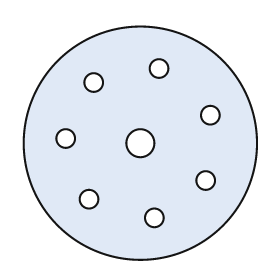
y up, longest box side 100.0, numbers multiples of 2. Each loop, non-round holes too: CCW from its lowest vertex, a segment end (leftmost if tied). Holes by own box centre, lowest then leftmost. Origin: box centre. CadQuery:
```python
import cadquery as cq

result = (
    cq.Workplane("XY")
    .moveTo(0.0, 0.0)
    .circle(50.0)
    .moveTo(6.0, -32.0)
    .circle(4.0)
    .moveTo(-22.0, -24.0)
    .circle(4.0)
    .moveTo(28.0, -16.0)
    .circle(4.0)
    .moveTo(0.0, 0.0)
    .circle(6.0)
    .moveTo(-32.0, 2.0)
    .circle(4.0)
    .moveTo(30.0, 12.0)
    .circle(4.0)
    .moveTo(-20.0, 26.0)
    .circle(4.0)
    .moveTo(8.0, 32.0)
    .circle(4.0)
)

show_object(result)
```